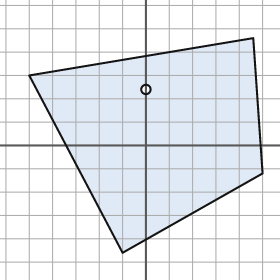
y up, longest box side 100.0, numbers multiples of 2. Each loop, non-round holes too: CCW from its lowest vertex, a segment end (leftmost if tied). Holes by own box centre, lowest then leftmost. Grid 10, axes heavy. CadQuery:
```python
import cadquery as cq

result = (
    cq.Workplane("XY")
    .moveTo(-10.0, -46.0)
    .lineTo(50.0, -12.0)
    .lineTo(46.0, 46.0)
    .lineTo(-50.0, 30.0)
    .close()
    .moveTo(0.0, 24.0)
    .circle(2.0)
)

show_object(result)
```